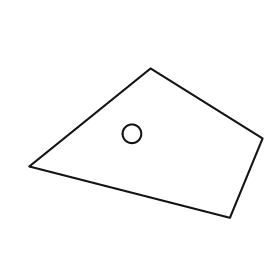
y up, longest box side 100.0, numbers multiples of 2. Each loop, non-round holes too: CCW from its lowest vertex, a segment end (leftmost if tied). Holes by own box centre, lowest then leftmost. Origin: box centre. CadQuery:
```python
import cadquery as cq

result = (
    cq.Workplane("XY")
    .moveTo(36.0, -32.0)
    .lineTo(50.0, 2.0)
    .lineTo(2.0, 32.0)
    .lineTo(-50.0, -10.0)
    .close()
    .moveTo(-6.0, 4.0)
    .circle(4.0)
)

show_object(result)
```